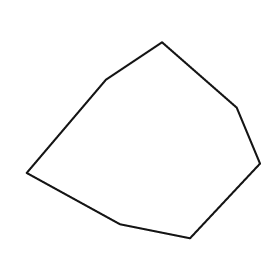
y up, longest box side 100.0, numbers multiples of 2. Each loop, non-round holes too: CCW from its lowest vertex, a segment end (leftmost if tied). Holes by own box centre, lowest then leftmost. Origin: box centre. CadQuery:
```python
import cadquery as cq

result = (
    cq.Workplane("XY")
    .moveTo(20.0, -42.0)
    .lineTo(50.0, -10.0)
    .lineTo(40.0, 14.0)
    .lineTo(8.0, 42.0)
    .lineTo(-16.0, 26.0)
    .lineTo(-50.0, -14.0)
    .lineTo(-10.0, -36.0)
    .close()
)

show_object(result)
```